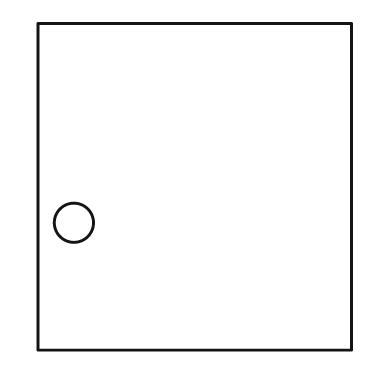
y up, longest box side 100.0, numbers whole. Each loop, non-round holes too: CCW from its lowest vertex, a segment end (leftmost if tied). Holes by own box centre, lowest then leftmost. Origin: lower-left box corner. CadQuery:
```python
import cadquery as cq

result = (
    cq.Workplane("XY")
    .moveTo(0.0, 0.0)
    .lineTo(96.0, 0.0)
    .lineTo(96.0, 100.0)
    .lineTo(0.0, 100.0)
    .close()
    .moveTo(11.0, 39.0)
    .circle(6.0)
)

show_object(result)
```